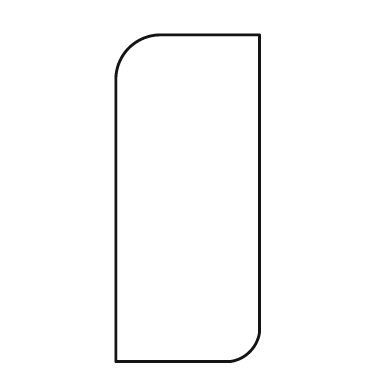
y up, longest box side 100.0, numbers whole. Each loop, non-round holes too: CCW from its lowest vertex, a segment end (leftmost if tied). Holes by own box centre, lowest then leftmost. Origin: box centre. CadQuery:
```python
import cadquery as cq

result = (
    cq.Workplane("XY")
    .moveTo(-22.0, -50.0)
    .lineTo(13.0, -50.0)
    .threePointArc((19.0, -47.0), (22.0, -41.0))
    .lineTo(22.0, 50.0)
    .lineTo(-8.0, 50.0)
    .threePointArc((-18.0, 46.0), (-22.0, 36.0))
    .close()
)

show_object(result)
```